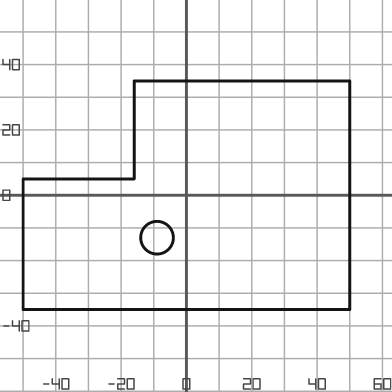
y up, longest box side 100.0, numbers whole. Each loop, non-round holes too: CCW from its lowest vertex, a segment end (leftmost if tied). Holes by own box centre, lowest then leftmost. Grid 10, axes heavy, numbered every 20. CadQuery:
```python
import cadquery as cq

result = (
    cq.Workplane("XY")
    .moveTo(-50.0, -35.0)
    .lineTo(50.0, -35.0)
    .lineTo(50.0, 35.0)
    .lineTo(-16.0, 35.0)
    .lineTo(-16.0, 5.0)
    .lineTo(-50.0, 5.0)
    .close()
    .moveTo(-9.0, -13.0)
    .circle(5.0)
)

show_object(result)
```